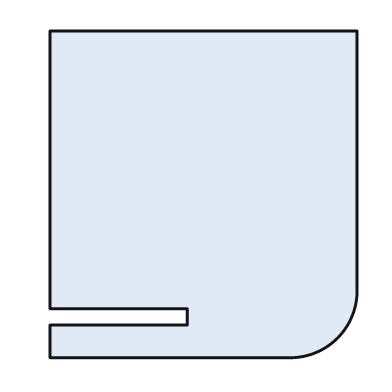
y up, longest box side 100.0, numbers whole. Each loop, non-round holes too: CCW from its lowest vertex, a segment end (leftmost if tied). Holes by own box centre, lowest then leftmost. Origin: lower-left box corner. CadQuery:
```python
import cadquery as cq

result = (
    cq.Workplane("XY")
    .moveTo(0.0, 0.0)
    .lineTo(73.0, 0.0)
    .threePointArc((88.0, 6.0), (94.0, 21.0))
    .lineTo(94.0, 100.0)
    .lineTo(0.0, 100.0)
    .lineTo(0.0, 15.0)
    .lineTo(42.0, 15.0)
    .lineTo(42.0, 10.0)
    .lineTo(0.0, 10.0)
    .close()
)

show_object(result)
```